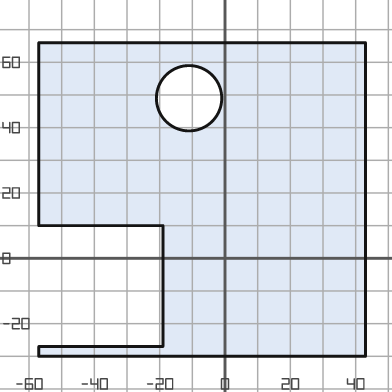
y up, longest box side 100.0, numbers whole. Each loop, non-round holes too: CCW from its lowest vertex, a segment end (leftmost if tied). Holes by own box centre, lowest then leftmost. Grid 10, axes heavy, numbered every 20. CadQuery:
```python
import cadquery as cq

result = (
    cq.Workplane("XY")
    .moveTo(-57.0, -30.0)
    .lineTo(43.0, -30.0)
    .lineTo(43.0, 66.0)
    .lineTo(-57.0, 66.0)
    .lineTo(-57.0, 10.0)
    .lineTo(-19.0, 10.0)
    .lineTo(-19.0, -27.0)
    .lineTo(-57.0, -27.0)
    .close()
    .moveTo(-11.0, 49.0)
    .circle(10.0)
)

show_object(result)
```